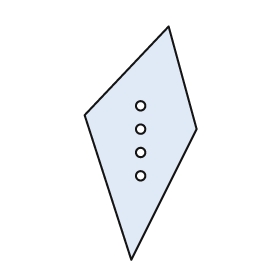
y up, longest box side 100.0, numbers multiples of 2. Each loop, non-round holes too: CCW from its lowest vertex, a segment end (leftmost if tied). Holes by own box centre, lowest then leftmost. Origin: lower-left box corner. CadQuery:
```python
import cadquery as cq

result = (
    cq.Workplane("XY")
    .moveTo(20.0, 0.0)
    .lineTo(48.0, 56.0)
    .lineTo(36.0, 100.0)
    .lineTo(0.0, 62.0)
    .close()
    .moveTo(24.0, 36.0)
    .circle(2.0)
    .moveTo(24.0, 46.0)
    .circle(2.0)
    .moveTo(24.0, 56.0)
    .circle(2.0)
    .moveTo(24.0, 66.0)
    .circle(2.0)
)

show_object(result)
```